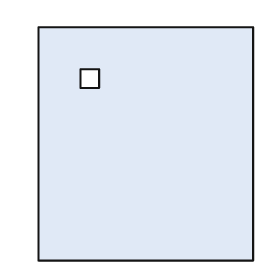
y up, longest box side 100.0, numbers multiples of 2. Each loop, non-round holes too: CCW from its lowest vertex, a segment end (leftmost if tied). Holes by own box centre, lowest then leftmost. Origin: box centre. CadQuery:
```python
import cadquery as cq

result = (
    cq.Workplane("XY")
    .moveTo(-46.0, -50.0)
    .lineTo(46.0, -50.0)
    .lineTo(46.0, 50.0)
    .lineTo(-46.0, 50.0)
    .close()
    .moveTo(-28.0, 24.0)
    .lineTo(-20.0, 24.0)
    .lineTo(-20.0, 32.0)
    .lineTo(-28.0, 32.0)
    .close()
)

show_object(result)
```